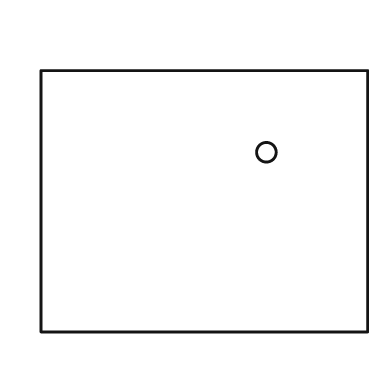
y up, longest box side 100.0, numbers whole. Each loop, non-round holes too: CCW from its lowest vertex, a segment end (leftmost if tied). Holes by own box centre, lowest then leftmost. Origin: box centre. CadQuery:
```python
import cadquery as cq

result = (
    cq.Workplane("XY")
    .moveTo(-50.0, -40.0)
    .lineTo(50.0, -40.0)
    .lineTo(50.0, 40.0)
    .lineTo(-50.0, 40.0)
    .close()
    .moveTo(19.0, 15.0)
    .circle(3.0)
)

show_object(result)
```